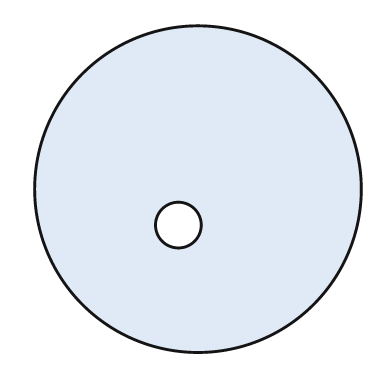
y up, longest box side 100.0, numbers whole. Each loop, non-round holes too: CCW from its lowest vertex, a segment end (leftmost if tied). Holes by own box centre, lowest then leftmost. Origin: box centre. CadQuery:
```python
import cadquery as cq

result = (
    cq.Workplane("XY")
    .moveTo(0.0, 0.0)
    .circle(50.0)
    .moveTo(-6.0, -11.0)
    .circle(7.0)
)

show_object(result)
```